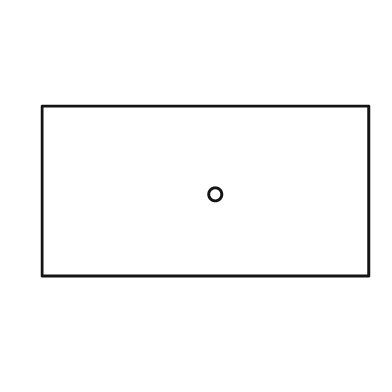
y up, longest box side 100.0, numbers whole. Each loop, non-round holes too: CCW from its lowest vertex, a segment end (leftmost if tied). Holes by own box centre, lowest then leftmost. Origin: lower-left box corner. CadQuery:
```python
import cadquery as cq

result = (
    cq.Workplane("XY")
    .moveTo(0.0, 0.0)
    .lineTo(100.0, 0.0)
    .lineTo(100.0, 52.0)
    .lineTo(0.0, 52.0)
    .close()
    .moveTo(53.0, 25.0)
    .circle(2.0)
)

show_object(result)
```